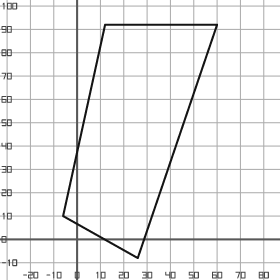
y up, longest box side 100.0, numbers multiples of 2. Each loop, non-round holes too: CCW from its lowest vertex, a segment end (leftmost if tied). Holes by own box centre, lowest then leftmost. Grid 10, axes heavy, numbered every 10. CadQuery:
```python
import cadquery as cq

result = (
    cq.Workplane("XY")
    .moveTo(26.0, -8.0)
    .lineTo(60.0, 92.0)
    .lineTo(12.0, 92.0)
    .lineTo(-6.0, 10.0)
    .close()
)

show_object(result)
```